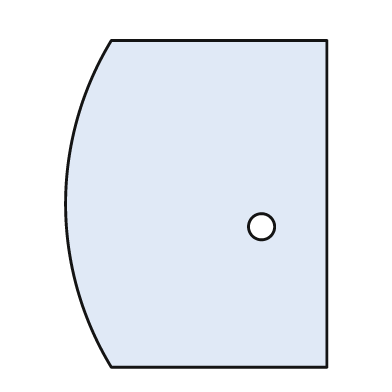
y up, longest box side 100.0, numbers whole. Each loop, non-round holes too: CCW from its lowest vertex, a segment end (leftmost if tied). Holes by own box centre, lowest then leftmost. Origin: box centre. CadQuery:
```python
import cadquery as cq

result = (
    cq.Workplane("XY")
    .moveTo(-26.0, -50.0)
    .lineTo(40.0, -50.0)
    .lineTo(40.0, 50.0)
    .lineTo(-26.0, 50.0)
    .threePointArc((-40.0, 0.0), (-26.0, -50.0))
    .close()
    .moveTo(20.0, -7.0)
    .circle(4.0)
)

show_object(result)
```